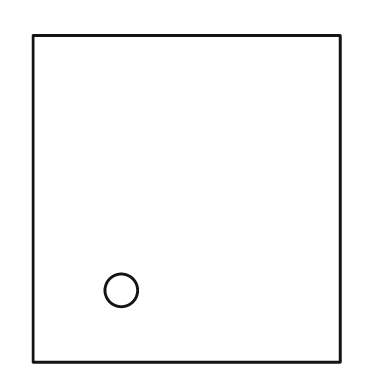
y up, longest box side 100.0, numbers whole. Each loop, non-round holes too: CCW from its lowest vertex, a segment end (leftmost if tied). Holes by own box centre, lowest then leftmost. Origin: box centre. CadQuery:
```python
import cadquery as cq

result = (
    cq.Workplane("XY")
    .moveTo(-47.0, -50.0)
    .lineTo(47.0, -50.0)
    .lineTo(47.0, 50.0)
    .lineTo(-47.0, 50.0)
    .close()
    .moveTo(-20.0, -28.0)
    .circle(5.0)
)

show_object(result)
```